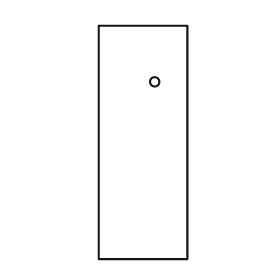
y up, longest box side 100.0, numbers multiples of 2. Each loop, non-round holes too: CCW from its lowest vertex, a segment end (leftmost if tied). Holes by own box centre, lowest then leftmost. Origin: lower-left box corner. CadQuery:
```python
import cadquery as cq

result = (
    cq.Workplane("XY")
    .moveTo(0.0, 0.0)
    .lineTo(38.0, 0.0)
    .lineTo(38.0, 100.0)
    .lineTo(0.0, 100.0)
    .close()
    .moveTo(24.0, 76.0)
    .circle(2.0)
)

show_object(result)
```